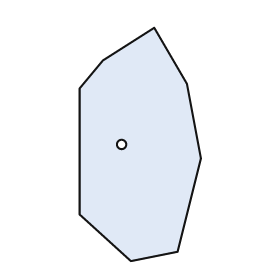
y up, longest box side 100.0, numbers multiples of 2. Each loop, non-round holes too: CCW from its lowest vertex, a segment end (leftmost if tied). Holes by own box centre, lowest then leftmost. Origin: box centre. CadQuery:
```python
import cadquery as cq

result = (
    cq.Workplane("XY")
    .moveTo(-4.0, -50.0)
    .lineTo(16.0, -46.0)
    .lineTo(26.0, -6.0)
    .lineTo(20.0, 26.0)
    .lineTo(6.0, 50.0)
    .lineTo(-16.0, 36.0)
    .lineTo(-26.0, 24.0)
    .lineTo(-26.0, -30.0)
    .close()
    .moveTo(-8.0, 0.0)
    .circle(2.0)
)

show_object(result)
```